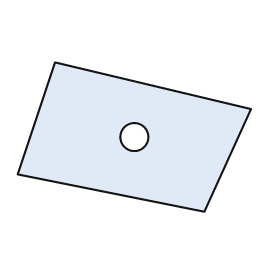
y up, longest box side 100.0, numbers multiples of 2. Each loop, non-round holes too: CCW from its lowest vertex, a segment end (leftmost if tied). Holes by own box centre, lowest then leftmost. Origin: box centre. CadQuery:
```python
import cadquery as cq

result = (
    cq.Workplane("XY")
    .moveTo(30.0, -32.0)
    .lineTo(50.0, 12.0)
    .lineTo(-34.0, 32.0)
    .lineTo(-50.0, -16.0)
    .close()
    .moveTo(0.0, 0.0)
    .circle(6.0)
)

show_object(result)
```